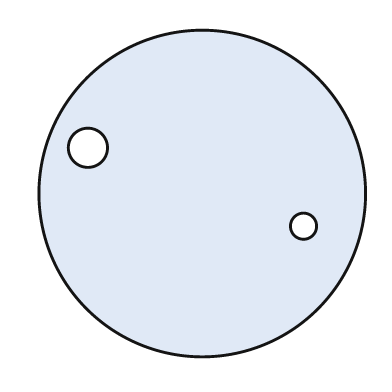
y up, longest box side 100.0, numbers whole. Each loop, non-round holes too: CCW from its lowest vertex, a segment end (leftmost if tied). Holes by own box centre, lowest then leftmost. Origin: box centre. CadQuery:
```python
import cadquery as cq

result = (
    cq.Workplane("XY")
    .moveTo(0.0, 0.0)
    .circle(50.0)
    .moveTo(31.0, -10.0)
    .circle(4.0)
    .moveTo(-35.0, 14.0)
    .circle(6.0)
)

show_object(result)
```